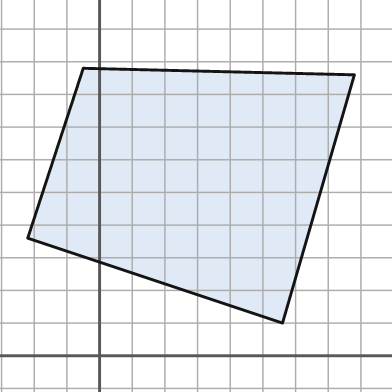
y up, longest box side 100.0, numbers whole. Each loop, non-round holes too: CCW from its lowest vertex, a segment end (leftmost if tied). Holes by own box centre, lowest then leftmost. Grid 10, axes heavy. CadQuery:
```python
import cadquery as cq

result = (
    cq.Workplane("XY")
    .moveTo(56.0, 10.0)
    .lineTo(78.0, 86.0)
    .lineTo(-5.0, 88.0)
    .lineTo(-22.0, 36.0)
    .close()
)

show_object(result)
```